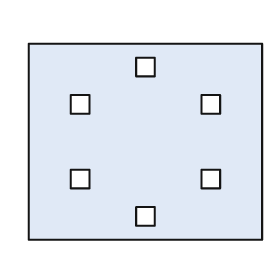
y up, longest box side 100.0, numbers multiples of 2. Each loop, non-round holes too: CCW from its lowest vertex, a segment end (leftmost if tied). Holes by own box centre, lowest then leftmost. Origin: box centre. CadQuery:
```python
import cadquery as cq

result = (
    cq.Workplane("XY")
    .moveTo(-50.0, -42.0)
    .lineTo(50.0, -42.0)
    .lineTo(50.0, 42.0)
    .lineTo(-50.0, 42.0)
    .close()
    .moveTo(-4.0, -36.0)
    .lineTo(4.0, -36.0)
    .lineTo(4.0, -28.0)
    .lineTo(-4.0, -28.0)
    .close()
    .moveTo(-32.0, -20.0)
    .lineTo(-24.0, -20.0)
    .lineTo(-24.0, -12.0)
    .lineTo(-32.0, -12.0)
    .close()
    .moveTo(24.0, -20.0)
    .lineTo(32.0, -20.0)
    .lineTo(32.0, -12.0)
    .lineTo(24.0, -12.0)
    .close()
    .moveTo(-32.0, 12.0)
    .lineTo(-24.0, 12.0)
    .lineTo(-24.0, 20.0)
    .lineTo(-32.0, 20.0)
    .close()
    .moveTo(24.0, 12.0)
    .lineTo(32.0, 12.0)
    .lineTo(32.0, 20.0)
    .lineTo(24.0, 20.0)
    .close()
    .moveTo(-4.0, 28.0)
    .lineTo(4.0, 28.0)
    .lineTo(4.0, 36.0)
    .lineTo(-4.0, 36.0)
    .close()
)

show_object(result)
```